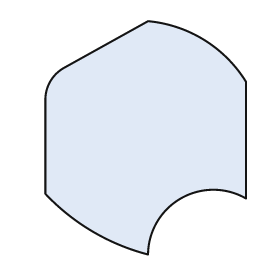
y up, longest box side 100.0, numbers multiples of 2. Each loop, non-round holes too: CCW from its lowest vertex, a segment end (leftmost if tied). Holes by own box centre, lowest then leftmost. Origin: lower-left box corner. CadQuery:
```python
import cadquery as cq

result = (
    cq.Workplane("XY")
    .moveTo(44.0, 0.0)
    .threePointArc((58.0, 24.0), (86.0, 24.0))
    .lineTo(86.0, 74.0)
    .threePointArc((68.0, 92.0), (44.0, 100.0))
    .lineTo(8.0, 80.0)
    .threePointArc((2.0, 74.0), (0.0, 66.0))
    .lineTo(0.0, 26.0)
    .threePointArc((20.0, 10.0), (44.0, 0.0))
    .close()
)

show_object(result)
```